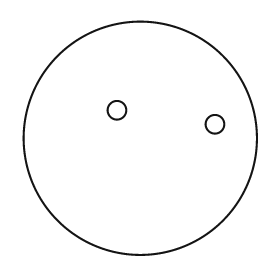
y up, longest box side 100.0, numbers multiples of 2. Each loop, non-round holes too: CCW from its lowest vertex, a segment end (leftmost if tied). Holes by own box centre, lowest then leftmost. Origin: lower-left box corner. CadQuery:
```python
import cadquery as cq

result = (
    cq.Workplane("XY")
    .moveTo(50.0, 50.0)
    .circle(50.0)
    .moveTo(82.0, 56.0)
    .circle(4.0)
    .moveTo(40.0, 62.0)
    .circle(4.0)
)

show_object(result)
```